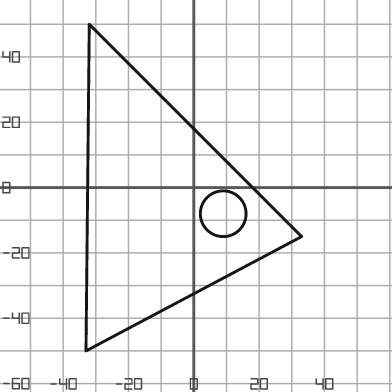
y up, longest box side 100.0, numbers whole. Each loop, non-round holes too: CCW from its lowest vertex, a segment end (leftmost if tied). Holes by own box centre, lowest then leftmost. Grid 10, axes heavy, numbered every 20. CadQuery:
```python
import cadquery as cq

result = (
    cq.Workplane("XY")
    .moveTo(-33.0, -50.0)
    .lineTo(33.0, -15.0)
    .lineTo(-32.0, 50.0)
    .close()
    .moveTo(9.0, -8.0)
    .circle(7.0)
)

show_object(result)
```